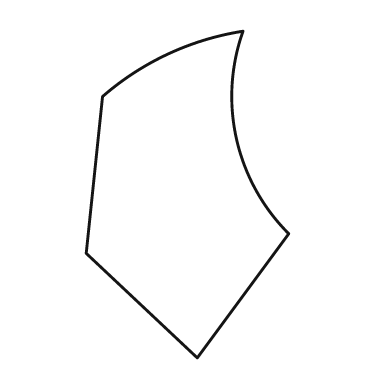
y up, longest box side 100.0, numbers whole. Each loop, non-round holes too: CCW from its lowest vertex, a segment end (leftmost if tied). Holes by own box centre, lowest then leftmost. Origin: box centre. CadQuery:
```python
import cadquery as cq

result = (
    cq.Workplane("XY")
    .moveTo(3.0, -50.0)
    .lineTo(31.0, -12.0)
    .threePointArc((15.0, 17.0), (17.0, 50.0))
    .threePointArc((-6.0, 43.0), (-26.0, 30.0))
    .lineTo(-31.0, -18.0)
    .close()
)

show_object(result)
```